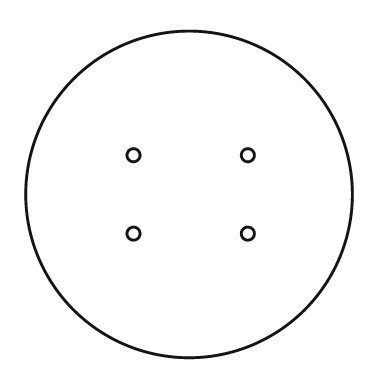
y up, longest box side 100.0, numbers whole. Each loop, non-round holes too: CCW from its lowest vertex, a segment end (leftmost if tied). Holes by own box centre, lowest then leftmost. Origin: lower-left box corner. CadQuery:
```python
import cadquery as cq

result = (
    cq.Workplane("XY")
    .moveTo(50.0, 50.0)
    .circle(50.0)
    .moveTo(33.0, 38.0)
    .circle(2.0)
    .moveTo(68.0, 38.0)
    .circle(2.0)
    .moveTo(33.0, 62.0)
    .circle(2.0)
    .moveTo(68.0, 62.0)
    .circle(2.0)
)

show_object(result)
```